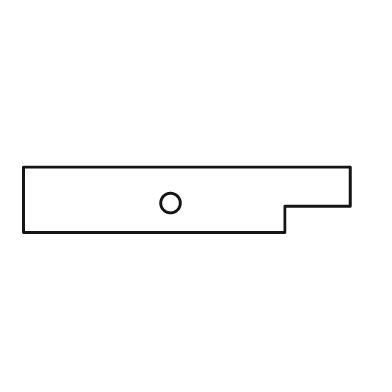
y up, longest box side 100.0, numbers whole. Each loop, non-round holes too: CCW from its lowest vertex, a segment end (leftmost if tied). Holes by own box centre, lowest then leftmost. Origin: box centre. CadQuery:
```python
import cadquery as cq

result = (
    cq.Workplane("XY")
    .moveTo(-50.0, -10.0)
    .lineTo(30.0, -10.0)
    .lineTo(30.0, -2.0)
    .lineTo(50.0, -2.0)
    .lineTo(50.0, 10.0)
    .lineTo(-50.0, 10.0)
    .close()
    .moveTo(-5.0, -1.0)
    .circle(3.0)
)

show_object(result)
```